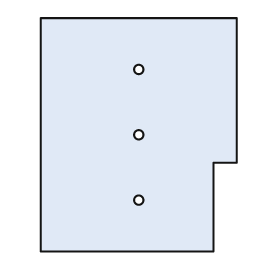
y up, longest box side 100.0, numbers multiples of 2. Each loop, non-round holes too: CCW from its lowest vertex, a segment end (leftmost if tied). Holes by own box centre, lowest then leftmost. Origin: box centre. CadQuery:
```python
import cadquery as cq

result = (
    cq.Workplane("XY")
    .moveTo(-42.0, -50.0)
    .lineTo(32.0, -50.0)
    .lineTo(32.0, -12.0)
    .lineTo(42.0, -12.0)
    .lineTo(42.0, 50.0)
    .lineTo(-42.0, 50.0)
    .close()
    .moveTo(0.0, -28.0)
    .circle(2.0)
    .moveTo(0.0, 0.0)
    .circle(2.0)
    .moveTo(0.0, 28.0)
    .circle(2.0)
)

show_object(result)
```